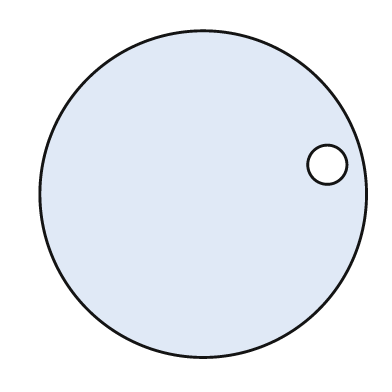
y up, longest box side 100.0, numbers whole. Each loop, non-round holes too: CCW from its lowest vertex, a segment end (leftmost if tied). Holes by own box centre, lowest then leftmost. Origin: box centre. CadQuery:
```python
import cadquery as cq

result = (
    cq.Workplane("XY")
    .moveTo(0.0, 0.0)
    .circle(50.0)
    .moveTo(38.0, 9.0)
    .circle(6.0)
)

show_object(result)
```